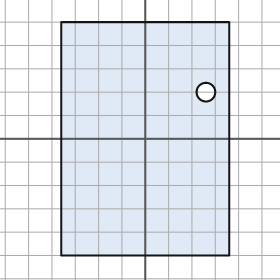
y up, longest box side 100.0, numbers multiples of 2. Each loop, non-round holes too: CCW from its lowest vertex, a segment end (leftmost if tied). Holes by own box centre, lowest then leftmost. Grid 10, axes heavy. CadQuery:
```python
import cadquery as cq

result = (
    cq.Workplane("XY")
    .moveTo(-36.0, -50.0)
    .lineTo(36.0, -50.0)
    .lineTo(36.0, 50.0)
    .lineTo(-36.0, 50.0)
    .close()
    .moveTo(26.0, 20.0)
    .circle(4.0)
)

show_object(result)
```